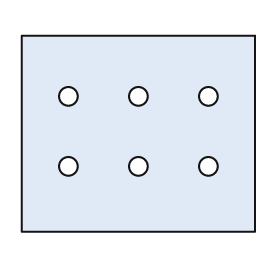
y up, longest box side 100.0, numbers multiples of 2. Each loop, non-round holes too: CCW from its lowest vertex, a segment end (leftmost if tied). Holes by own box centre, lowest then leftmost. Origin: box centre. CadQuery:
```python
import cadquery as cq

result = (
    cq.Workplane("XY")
    .moveTo(-50.0, -42.0)
    .lineTo(50.0, -42.0)
    .lineTo(50.0, 42.0)
    .lineTo(-50.0, 42.0)
    .close()
    .moveTo(-30.0, -14.0)
    .circle(4.0)
    .moveTo(0.0, -14.0)
    .circle(4.0)
    .moveTo(30.0, -14.0)
    .circle(4.0)
    .moveTo(-30.0, 16.0)
    .circle(4.0)
    .moveTo(0.0, 16.0)
    .circle(4.0)
    .moveTo(30.0, 16.0)
    .circle(4.0)
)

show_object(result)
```